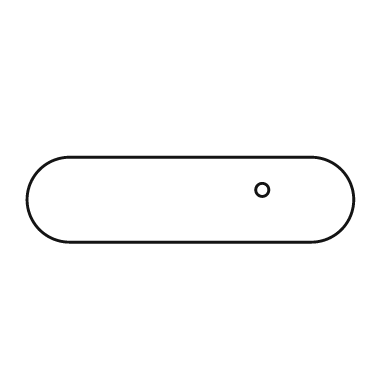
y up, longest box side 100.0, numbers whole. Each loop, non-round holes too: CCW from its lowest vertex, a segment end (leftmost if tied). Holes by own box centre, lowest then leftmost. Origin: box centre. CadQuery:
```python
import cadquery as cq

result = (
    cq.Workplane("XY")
    .moveTo(-37.0, -13.0)
    .lineTo(37.0, -13.0)
    .threePointArc((50.0, 0.0), (37.0, 13.0))
    .lineTo(-37.0, 13.0)
    .threePointArc((-50.0, 0.0), (-37.0, -13.0))
    .close()
    .moveTo(22.0, 3.0)
    .circle(2.0)
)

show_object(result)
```